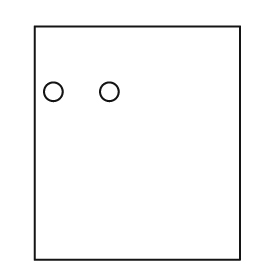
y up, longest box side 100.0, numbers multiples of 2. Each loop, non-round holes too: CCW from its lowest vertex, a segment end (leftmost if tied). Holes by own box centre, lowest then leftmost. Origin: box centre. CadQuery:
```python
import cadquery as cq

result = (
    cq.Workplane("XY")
    .moveTo(-44.0, -50.0)
    .lineTo(44.0, -50.0)
    .lineTo(44.0, 50.0)
    .lineTo(-44.0, 50.0)
    .close()
    .moveTo(-36.0, 22.0)
    .circle(4.0)
    .moveTo(-12.0, 22.0)
    .circle(4.0)
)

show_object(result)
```